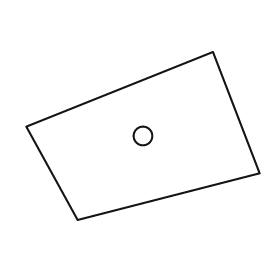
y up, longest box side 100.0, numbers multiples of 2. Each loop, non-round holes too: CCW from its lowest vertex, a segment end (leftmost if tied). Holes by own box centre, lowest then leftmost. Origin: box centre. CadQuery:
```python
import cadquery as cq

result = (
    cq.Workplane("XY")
    .moveTo(-28.0, -36.0)
    .lineTo(50.0, -16.0)
    .lineTo(30.0, 36.0)
    .lineTo(-50.0, 4.0)
    .close()
    .moveTo(0.0, 0.0)
    .circle(4.0)
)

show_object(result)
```